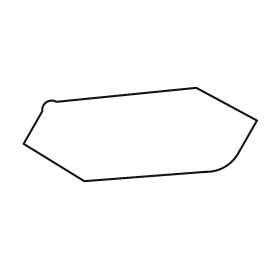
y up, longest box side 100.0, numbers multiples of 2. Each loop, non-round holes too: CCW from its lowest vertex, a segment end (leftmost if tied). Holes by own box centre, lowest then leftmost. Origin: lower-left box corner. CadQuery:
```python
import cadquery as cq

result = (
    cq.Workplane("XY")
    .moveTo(26.0, 0.0)
    .lineTo(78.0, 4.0)
    .threePointArc((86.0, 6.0), (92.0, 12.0))
    .lineTo(100.0, 26.0)
    .lineTo(74.0, 40.0)
    .lineTo(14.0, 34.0)
    .threePointArc((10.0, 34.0), (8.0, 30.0))
    .lineTo(0.0, 16.0)
    .close()
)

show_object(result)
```